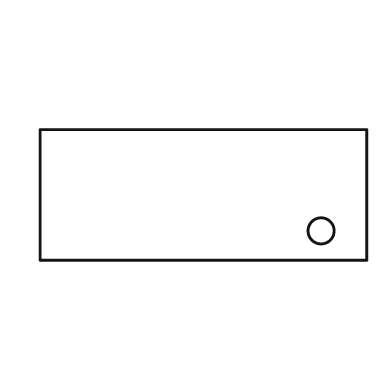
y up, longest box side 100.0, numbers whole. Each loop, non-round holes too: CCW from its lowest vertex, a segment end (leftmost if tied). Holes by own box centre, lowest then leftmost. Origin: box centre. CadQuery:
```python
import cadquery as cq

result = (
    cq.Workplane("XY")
    .moveTo(-50.0, -20.0)
    .lineTo(50.0, -20.0)
    .lineTo(50.0, 20.0)
    .lineTo(-50.0, 20.0)
    .close()
    .moveTo(36.0, -11.0)
    .circle(4.0)
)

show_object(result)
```